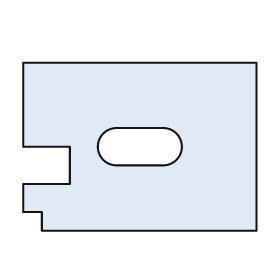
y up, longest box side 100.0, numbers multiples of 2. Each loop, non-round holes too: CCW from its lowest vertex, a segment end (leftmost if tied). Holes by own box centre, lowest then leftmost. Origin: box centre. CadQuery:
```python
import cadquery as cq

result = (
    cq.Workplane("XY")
    .moveTo(-42.0, -36.0)
    .lineTo(50.0, -36.0)
    .lineTo(50.0, 36.0)
    .lineTo(-50.0, 36.0)
    .lineTo(-50.0, 0.0)
    .lineTo(-30.0, 0.0)
    .lineTo(-30.0, -16.0)
    .lineTo(-50.0, -16.0)
    .lineTo(-50.0, -28.0)
    .lineTo(-42.0, -28.0)
    .close()
    .moveTo(-10.0, -8.0)
    .lineTo(10.0, -8.0)
    .threePointArc((18.0, 0.0), (10.0, 8.0))
    .lineTo(-10.0, 8.0)
    .threePointArc((-18.0, 0.0), (-10.0, -8.0))
    .close()
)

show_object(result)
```